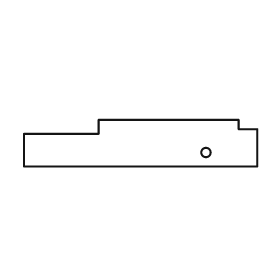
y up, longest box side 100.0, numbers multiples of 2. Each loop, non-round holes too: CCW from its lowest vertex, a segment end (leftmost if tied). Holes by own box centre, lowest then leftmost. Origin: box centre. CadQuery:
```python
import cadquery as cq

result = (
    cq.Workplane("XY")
    .moveTo(-50.0, -10.0)
    .lineTo(50.0, -10.0)
    .lineTo(50.0, 6.0)
    .lineTo(42.0, 6.0)
    .lineTo(42.0, 10.0)
    .lineTo(-18.0, 10.0)
    .lineTo(-18.0, 4.0)
    .lineTo(-50.0, 4.0)
    .close()
    .moveTo(28.0, -4.0)
    .circle(2.0)
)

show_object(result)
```